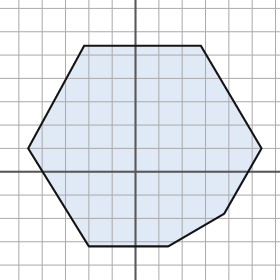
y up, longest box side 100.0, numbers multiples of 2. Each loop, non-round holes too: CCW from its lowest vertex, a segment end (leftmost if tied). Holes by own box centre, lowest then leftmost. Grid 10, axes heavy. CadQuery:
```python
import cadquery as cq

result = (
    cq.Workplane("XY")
    .moveTo(-20.0, -32.0)
    .lineTo(14.0, -32.0)
    .lineTo(38.0, -18.0)
    .lineTo(54.0, 10.0)
    .lineTo(28.0, 54.0)
    .lineTo(-22.0, 54.0)
    .lineTo(-46.0, 10.0)
    .close()
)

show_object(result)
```